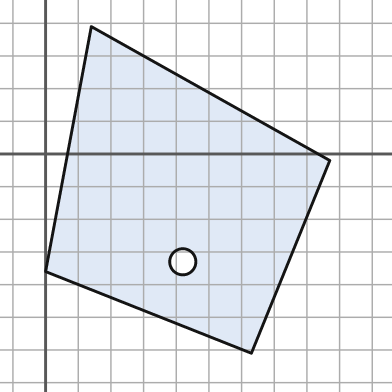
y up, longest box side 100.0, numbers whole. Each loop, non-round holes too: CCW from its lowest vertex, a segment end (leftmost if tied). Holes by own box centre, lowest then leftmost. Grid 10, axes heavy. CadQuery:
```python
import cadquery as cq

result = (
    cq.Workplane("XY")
    .moveTo(63.0, -61.0)
    .lineTo(87.0, -2.0)
    .lineTo(14.0, 39.0)
    .lineTo(0.0, -36.0)
    .close()
    .moveTo(42.0, -33.0)
    .circle(4.0)
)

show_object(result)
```